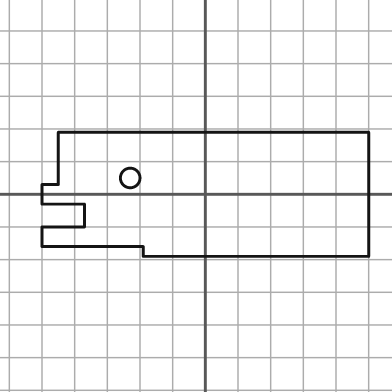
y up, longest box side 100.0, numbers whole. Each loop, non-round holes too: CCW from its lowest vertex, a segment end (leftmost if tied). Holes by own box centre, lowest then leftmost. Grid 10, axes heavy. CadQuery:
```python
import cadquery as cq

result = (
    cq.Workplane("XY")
    .moveTo(-19.0, -19.0)
    .lineTo(50.0, -19.0)
    .lineTo(50.0, 19.0)
    .lineTo(-45.0, 19.0)
    .lineTo(-45.0, 3.0)
    .lineTo(-50.0, 3.0)
    .lineTo(-50.0, -3.0)
    .lineTo(-37.0, -3.0)
    .lineTo(-37.0, -10.0)
    .lineTo(-50.0, -10.0)
    .lineTo(-50.0, -16.0)
    .lineTo(-19.0, -16.0)
    .close()
    .moveTo(-23.0, 5.0)
    .circle(3.0)
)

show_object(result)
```